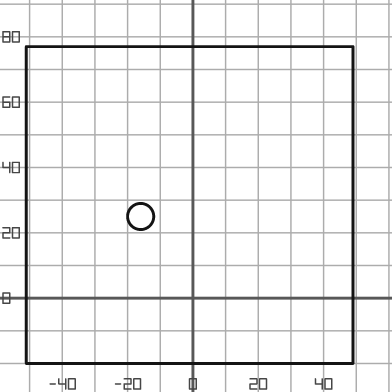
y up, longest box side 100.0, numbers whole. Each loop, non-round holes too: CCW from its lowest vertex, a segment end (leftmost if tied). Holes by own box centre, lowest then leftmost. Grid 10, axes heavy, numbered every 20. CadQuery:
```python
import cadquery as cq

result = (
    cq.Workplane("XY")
    .moveTo(-51.0, -20.0)
    .lineTo(49.0, -20.0)
    .lineTo(49.0, 77.0)
    .lineTo(-51.0, 77.0)
    .close()
    .moveTo(-16.0, 25.0)
    .circle(4.0)
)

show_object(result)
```